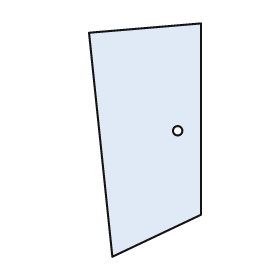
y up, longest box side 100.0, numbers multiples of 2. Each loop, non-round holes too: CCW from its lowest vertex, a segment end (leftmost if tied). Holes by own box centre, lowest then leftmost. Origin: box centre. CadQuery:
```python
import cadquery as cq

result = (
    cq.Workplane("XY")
    .moveTo(-14.0, -50.0)
    .lineTo(24.0, -32.0)
    .lineTo(24.0, 50.0)
    .lineTo(-24.0, 46.0)
    .close()
    .moveTo(14.0, 4.0)
    .circle(2.0)
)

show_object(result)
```